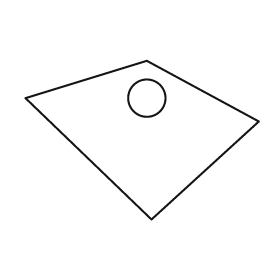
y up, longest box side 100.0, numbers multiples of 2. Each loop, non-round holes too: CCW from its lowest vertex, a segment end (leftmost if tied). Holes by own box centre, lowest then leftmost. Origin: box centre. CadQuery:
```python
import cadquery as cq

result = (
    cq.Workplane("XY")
    .moveTo(4.0, -34.0)
    .lineTo(50.0, 8.0)
    .lineTo(2.0, 34.0)
    .lineTo(-50.0, 18.0)
    .close()
    .moveTo(2.0, 18.0)
    .circle(8.0)
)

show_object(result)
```